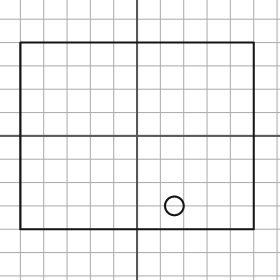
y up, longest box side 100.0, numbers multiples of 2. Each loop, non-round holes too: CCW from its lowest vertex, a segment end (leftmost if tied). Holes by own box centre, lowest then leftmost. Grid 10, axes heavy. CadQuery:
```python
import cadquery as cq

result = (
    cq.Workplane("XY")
    .moveTo(-50.0, -40.0)
    .lineTo(50.0, -40.0)
    .lineTo(50.0, 40.0)
    .lineTo(-50.0, 40.0)
    .close()
    .moveTo(16.0, -30.0)
    .circle(4.0)
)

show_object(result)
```